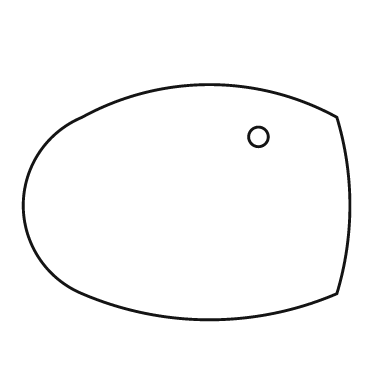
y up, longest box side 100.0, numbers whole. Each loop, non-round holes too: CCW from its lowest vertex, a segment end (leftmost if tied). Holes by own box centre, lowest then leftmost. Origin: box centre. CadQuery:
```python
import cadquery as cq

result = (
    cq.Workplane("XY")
    .moveTo(-32.0, -28.0)
    .threePointArc((7.0, -36.0), (46.0, -28.0))
    .threePointArc((50.0, -1.0), (46.0, 26.0))
    .threePointArc((7.0, 36.0), (-32.0, 26.0))
    .threePointArc((-50.0, -1.0), (-32.0, -28.0))
    .close()
    .moveTo(22.0, 20.0)
    .circle(3.0)
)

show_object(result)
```